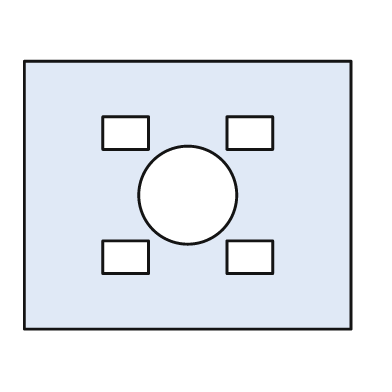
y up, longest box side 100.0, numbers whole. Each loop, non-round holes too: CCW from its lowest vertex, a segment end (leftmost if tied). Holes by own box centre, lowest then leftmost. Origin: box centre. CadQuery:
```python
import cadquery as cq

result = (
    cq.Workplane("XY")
    .moveTo(-50.0, -41.0)
    .lineTo(50.0, -41.0)
    .lineTo(50.0, 41.0)
    .lineTo(-50.0, 41.0)
    .close()
    .moveTo(-26.0, -24.0)
    .lineTo(-12.0, -24.0)
    .lineTo(-12.0, -14.0)
    .lineTo(-26.0, -14.0)
    .close()
    .moveTo(12.0, -24.0)
    .lineTo(26.0, -24.0)
    .lineTo(26.0, -14.0)
    .lineTo(12.0, -14.0)
    .close()
    .moveTo(0.0, 0.0)
    .circle(15.0)
    .moveTo(-26.0, 14.0)
    .lineTo(-12.0, 14.0)
    .lineTo(-12.0, 24.0)
    .lineTo(-26.0, 24.0)
    .close()
    .moveTo(12.0, 14.0)
    .lineTo(26.0, 14.0)
    .lineTo(26.0, 24.0)
    .lineTo(12.0, 24.0)
    .close()
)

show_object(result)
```